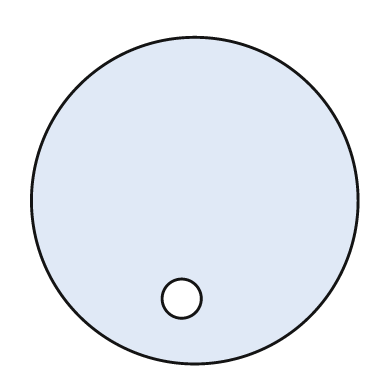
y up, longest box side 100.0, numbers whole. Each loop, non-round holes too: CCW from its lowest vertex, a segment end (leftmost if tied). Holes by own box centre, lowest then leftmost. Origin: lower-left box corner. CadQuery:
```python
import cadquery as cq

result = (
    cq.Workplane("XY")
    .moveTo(50.0, 50.0)
    .circle(50.0)
    .moveTo(46.0, 20.0)
    .circle(6.0)
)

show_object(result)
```